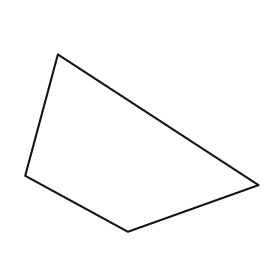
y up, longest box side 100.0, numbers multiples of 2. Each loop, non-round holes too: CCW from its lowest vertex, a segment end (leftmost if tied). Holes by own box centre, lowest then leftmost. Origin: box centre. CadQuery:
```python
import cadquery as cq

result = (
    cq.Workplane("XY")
    .moveTo(-6.0, -38.0)
    .lineTo(50.0, -18.0)
    .lineTo(-36.0, 38.0)
    .lineTo(-50.0, -14.0)
    .close()
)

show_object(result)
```